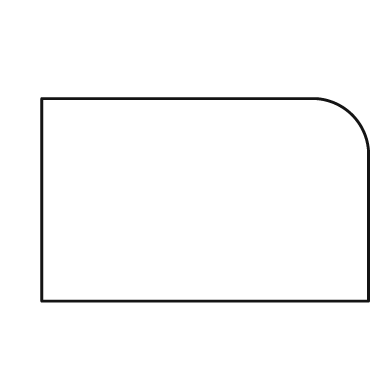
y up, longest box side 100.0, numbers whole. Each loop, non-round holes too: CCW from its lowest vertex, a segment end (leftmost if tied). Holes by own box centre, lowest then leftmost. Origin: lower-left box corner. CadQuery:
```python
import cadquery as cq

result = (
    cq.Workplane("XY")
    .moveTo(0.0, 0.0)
    .lineTo(100.0, 0.0)
    .lineTo(100.0, 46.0)
    .threePointArc((95.0, 57.0), (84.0, 62.0))
    .lineTo(0.0, 62.0)
    .close()
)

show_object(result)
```